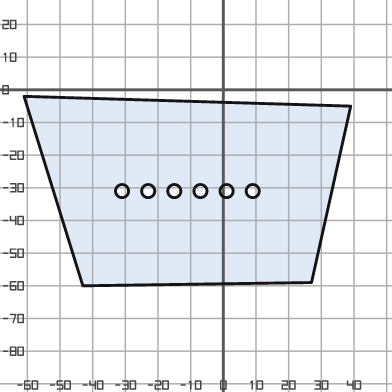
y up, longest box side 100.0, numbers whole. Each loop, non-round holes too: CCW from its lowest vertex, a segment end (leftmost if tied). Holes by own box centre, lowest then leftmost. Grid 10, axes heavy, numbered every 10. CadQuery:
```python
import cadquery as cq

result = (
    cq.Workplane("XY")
    .moveTo(-43.0, -60.0)
    .lineTo(27.0, -59.0)
    .lineTo(39.0, -5.0)
    .lineTo(-61.0, -2.0)
    .close()
    .moveTo(-31.0, -31.0)
    .circle(2.0)
    .moveTo(-23.0, -31.0)
    .circle(2.0)
    .moveTo(-15.0, -31.0)
    .circle(2.0)
    .moveTo(-7.0, -31.0)
    .circle(2.0)
    .moveTo(1.0, -31.0)
    .circle(2.0)
    .moveTo(9.0, -31.0)
    .circle(2.0)
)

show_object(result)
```